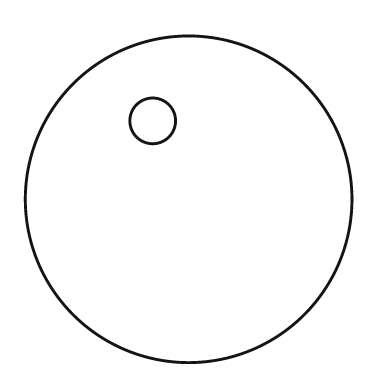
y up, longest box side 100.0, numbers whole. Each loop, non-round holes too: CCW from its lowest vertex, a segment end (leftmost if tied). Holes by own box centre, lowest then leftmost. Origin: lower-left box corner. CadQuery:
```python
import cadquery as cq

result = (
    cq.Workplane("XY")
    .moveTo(50.0, 50.0)
    .circle(50.0)
    .moveTo(39.0, 74.0)
    .circle(7.0)
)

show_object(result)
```